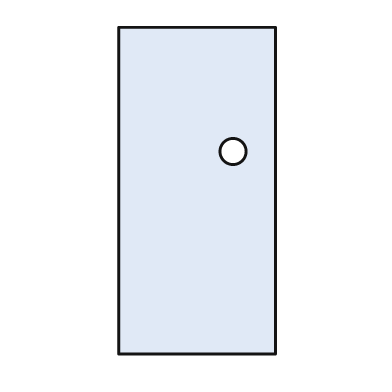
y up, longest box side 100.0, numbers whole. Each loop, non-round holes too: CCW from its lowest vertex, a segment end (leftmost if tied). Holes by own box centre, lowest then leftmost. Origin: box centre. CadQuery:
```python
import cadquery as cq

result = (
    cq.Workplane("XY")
    .moveTo(-24.0, -50.0)
    .lineTo(24.0, -50.0)
    .lineTo(24.0, 50.0)
    .lineTo(-24.0, 50.0)
    .close()
    .moveTo(11.0, 12.0)
    .circle(4.0)
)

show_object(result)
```